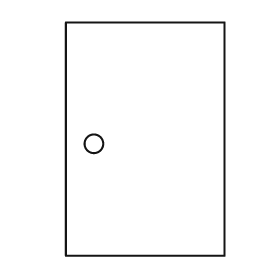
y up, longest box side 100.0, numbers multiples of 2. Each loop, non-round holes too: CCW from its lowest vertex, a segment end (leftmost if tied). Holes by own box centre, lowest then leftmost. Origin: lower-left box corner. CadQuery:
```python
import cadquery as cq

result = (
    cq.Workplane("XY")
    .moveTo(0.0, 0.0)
    .lineTo(68.0, 0.0)
    .lineTo(68.0, 100.0)
    .lineTo(0.0, 100.0)
    .close()
    .moveTo(12.0, 48.0)
    .circle(4.0)
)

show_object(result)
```